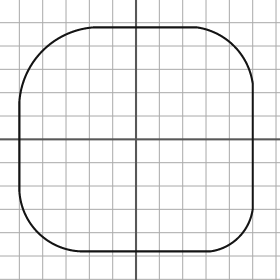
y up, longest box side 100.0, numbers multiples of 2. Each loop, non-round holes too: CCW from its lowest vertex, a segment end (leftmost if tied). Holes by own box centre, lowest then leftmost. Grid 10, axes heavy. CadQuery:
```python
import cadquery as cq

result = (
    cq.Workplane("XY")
    .moveTo(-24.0, -48.0)
    .lineTo(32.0, -48.0)
    .threePointArc((44.0, -42.0), (50.0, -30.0))
    .lineTo(50.0, 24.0)
    .threePointArc((42.0, 40.0), (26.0, 48.0))
    .lineTo(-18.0, 48.0)
    .threePointArc((-40.0, 38.0), (-50.0, 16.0))
    .lineTo(-50.0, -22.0)
    .threePointArc((-42.0, -40.0), (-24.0, -48.0))
    .close()
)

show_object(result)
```